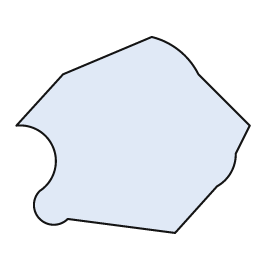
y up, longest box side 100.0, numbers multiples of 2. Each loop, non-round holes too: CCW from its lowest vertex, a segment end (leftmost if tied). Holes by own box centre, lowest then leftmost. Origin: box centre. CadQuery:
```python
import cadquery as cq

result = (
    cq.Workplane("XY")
    .moveTo(18.0, -42.0)
    .lineTo(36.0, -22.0)
    .threePointArc((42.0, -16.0), (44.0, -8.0))
    .lineTo(50.0, 4.0)
    .lineTo(28.0, 26.0)
    .threePointArc((20.0, 36.0), (8.0, 42.0))
    .lineTo(-30.0, 26.0)
    .lineTo(-50.0, 4.0)
    .threePointArc((-34.0, -6.0), (-40.0, -24.0))
    .threePointArc((-40.0, -36.0), (-28.0, -36.0))
    .close()
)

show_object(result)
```